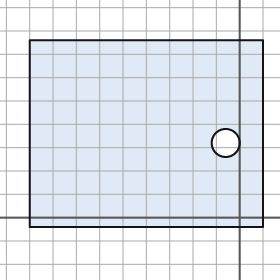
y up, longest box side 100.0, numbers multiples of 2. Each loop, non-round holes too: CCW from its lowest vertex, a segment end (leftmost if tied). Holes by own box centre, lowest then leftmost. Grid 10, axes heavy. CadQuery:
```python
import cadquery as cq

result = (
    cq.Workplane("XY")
    .moveTo(-90.0, -4.0)
    .lineTo(10.0, -4.0)
    .lineTo(10.0, 76.0)
    .lineTo(-90.0, 76.0)
    .close()
    .moveTo(-6.0, 32.0)
    .circle(6.0)
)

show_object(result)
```